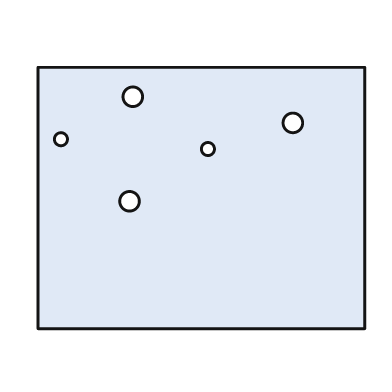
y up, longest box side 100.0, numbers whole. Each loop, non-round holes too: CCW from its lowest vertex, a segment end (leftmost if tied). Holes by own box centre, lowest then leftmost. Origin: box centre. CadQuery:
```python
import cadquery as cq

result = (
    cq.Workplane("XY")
    .moveTo(-50.0, -40.0)
    .lineTo(50.0, -40.0)
    .lineTo(50.0, 40.0)
    .lineTo(-50.0, 40.0)
    .close()
    .moveTo(-22.0, -1.0)
    .circle(3.0)
    .moveTo(2.0, 15.0)
    .circle(2.0)
    .moveTo(-43.0, 18.0)
    .circle(2.0)
    .moveTo(28.0, 23.0)
    .circle(3.0)
    .moveTo(-21.0, 31.0)
    .circle(3.0)
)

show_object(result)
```